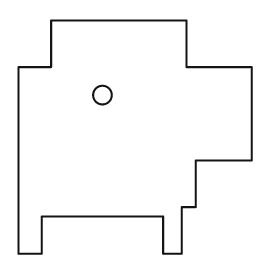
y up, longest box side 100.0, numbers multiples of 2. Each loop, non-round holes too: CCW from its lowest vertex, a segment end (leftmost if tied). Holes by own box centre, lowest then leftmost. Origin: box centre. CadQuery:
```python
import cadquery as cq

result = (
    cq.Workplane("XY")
    .moveTo(-50.0, -50.0)
    .lineTo(-40.0, -50.0)
    .lineTo(-40.0, -34.0)
    .lineTo(12.0, -34.0)
    .lineTo(12.0, -50.0)
    .lineTo(20.0, -50.0)
    .lineTo(20.0, -30.0)
    .lineTo(26.0, -30.0)
    .lineTo(26.0, -10.0)
    .lineTo(50.0, -10.0)
    .lineTo(50.0, 30.0)
    .lineTo(22.0, 30.0)
    .lineTo(22.0, 50.0)
    .lineTo(-36.0, 50.0)
    .lineTo(-36.0, 30.0)
    .lineTo(-50.0, 30.0)
    .close()
    .moveTo(-14.0, 18.0)
    .circle(4.0)
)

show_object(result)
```